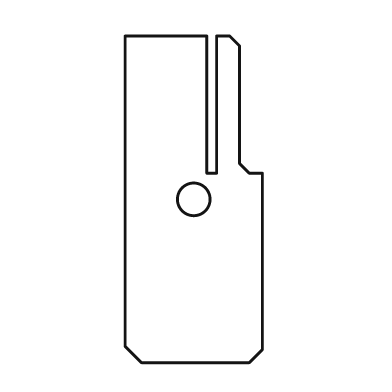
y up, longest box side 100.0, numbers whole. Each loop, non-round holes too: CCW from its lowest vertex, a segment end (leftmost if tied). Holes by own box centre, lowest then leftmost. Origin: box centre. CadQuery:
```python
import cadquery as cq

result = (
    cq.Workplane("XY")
    .moveTo(-16.0, -50.0)
    .lineTo(17.0, -50.0)
    .lineTo(21.0, -46.0)
    .lineTo(21.0, 8.0)
    .lineTo(17.0, 8.0)
    .lineTo(14.0, 11.0)
    .lineTo(14.0, 47.0)
    .lineTo(11.0, 50.0)
    .lineTo(7.0, 50.0)
    .lineTo(7.0, 8.0)
    .lineTo(4.0, 8.0)
    .lineTo(4.0, 50.0)
    .lineTo(-21.0, 50.0)
    .lineTo(-21.0, -45.0)
    .close()
    .moveTo(0.0, 0.0)
    .circle(5.0)
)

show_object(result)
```